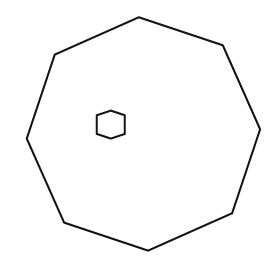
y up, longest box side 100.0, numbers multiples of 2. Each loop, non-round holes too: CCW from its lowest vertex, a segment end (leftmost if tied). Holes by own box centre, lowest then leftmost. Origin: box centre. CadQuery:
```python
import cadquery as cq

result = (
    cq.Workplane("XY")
    .moveTo(2.0, -50.0)
    .lineTo(38.0, -34.0)
    .lineTo(50.0, 2.0)
    .lineTo(34.0, 38.0)
    .lineTo(-2.0, 50.0)
    .lineTo(-38.0, 34.0)
    .lineTo(-50.0, -2.0)
    .lineTo(-34.0, -38.0)
    .close()
    .moveTo(-14.0, -2.0)
    .lineTo(-8.0, 0.0)
    .lineTo(-8.0, 8.0)
    .lineTo(-14.0, 10.0)
    .lineTo(-20.0, 8.0)
    .lineTo(-20.0, 0.0)
    .close()
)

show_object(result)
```